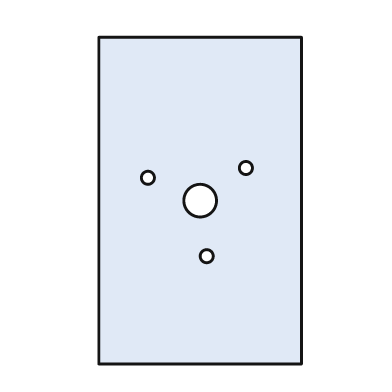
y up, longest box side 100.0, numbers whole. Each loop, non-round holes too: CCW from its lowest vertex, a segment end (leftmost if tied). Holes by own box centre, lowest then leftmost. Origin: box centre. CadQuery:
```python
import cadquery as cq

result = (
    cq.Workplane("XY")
    .moveTo(-31.0, -50.0)
    .lineTo(31.0, -50.0)
    .lineTo(31.0, 50.0)
    .lineTo(-31.0, 50.0)
    .close()
    .moveTo(2.0, -17.0)
    .circle(2.0)
    .moveTo(0.0, 0.0)
    .circle(5.0)
    .moveTo(-16.0, 7.0)
    .circle(2.0)
    .moveTo(14.0, 10.0)
    .circle(2.0)
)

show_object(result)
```